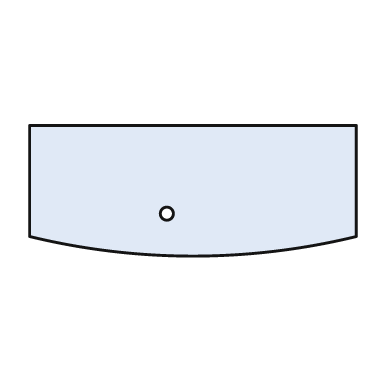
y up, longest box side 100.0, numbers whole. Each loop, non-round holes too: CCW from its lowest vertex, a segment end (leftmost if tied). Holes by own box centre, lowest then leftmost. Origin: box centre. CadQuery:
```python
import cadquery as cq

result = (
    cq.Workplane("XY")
    .moveTo(-50.0, -14.0)
    .threePointArc((0.0, -20.0), (50.0, -14.0))
    .lineTo(50.0, 20.0)
    .lineTo(-50.0, 20.0)
    .close()
    .moveTo(-8.0, -7.0)
    .circle(2.0)
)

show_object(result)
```